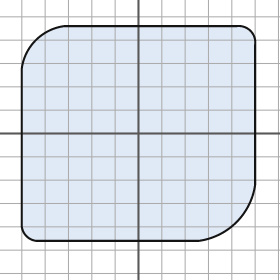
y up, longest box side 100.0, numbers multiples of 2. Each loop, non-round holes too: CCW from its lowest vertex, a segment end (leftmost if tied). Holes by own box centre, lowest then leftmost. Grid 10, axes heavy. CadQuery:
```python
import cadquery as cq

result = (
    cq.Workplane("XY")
    .moveTo(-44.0, -46.0)
    .lineTo(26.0, -46.0)
    .threePointArc((42.0, -38.0), (50.0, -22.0))
    .lineTo(50.0, 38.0)
    .threePointArc((48.0, 44.0), (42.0, 46.0))
    .lineTo(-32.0, 46.0)
    .threePointArc((-44.0, 40.0), (-50.0, 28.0))
    .lineTo(-50.0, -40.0)
    .threePointArc((-48.0, -44.0), (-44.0, -46.0))
    .close()
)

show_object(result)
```